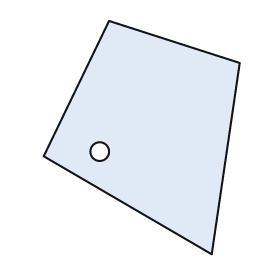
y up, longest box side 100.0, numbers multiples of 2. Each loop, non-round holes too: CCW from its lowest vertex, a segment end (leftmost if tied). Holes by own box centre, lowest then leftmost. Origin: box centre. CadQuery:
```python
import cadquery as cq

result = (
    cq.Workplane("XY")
    .moveTo(30.0, -50.0)
    .lineTo(42.0, 32.0)
    .lineTo(-14.0, 50.0)
    .lineTo(-42.0, -8.0)
    .close()
    .moveTo(-18.0, -6.0)
    .circle(4.0)
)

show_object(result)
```